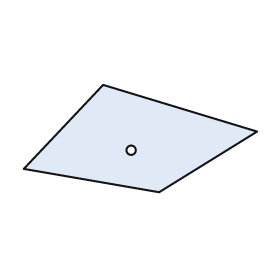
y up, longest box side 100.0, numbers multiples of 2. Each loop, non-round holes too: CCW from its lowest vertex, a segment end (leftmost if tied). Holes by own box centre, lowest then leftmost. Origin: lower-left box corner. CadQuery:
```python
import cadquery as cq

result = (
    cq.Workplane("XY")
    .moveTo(58.0, 0.0)
    .lineTo(100.0, 26.0)
    .lineTo(34.0, 46.0)
    .lineTo(0.0, 10.0)
    .close()
    .moveTo(46.0, 18.0)
    .circle(2.0)
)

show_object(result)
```